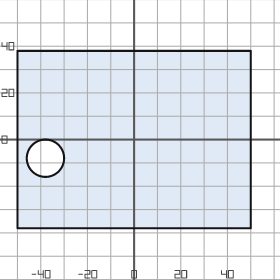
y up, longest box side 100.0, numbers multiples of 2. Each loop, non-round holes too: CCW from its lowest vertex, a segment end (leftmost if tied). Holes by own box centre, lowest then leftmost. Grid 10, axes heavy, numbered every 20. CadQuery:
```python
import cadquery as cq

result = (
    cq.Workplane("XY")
    .moveTo(-50.0, -38.0)
    .lineTo(50.0, -38.0)
    .lineTo(50.0, 38.0)
    .lineTo(-50.0, 38.0)
    .close()
    .moveTo(-38.0, -8.0)
    .circle(8.0)
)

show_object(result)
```